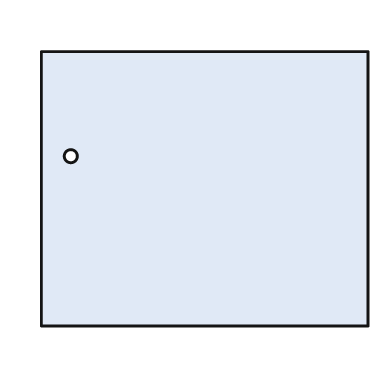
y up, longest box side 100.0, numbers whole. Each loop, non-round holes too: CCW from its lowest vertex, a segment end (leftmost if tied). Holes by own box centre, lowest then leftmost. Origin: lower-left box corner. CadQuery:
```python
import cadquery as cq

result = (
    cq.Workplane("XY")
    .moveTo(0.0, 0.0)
    .lineTo(100.0, 0.0)
    .lineTo(100.0, 84.0)
    .lineTo(0.0, 84.0)
    .close()
    .moveTo(9.0, 52.0)
    .circle(2.0)
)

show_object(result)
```